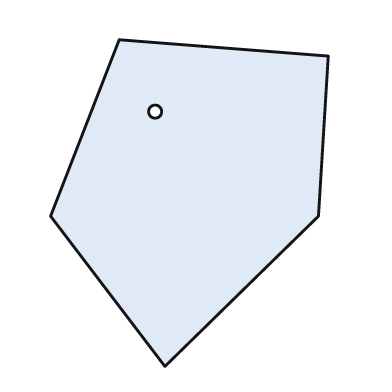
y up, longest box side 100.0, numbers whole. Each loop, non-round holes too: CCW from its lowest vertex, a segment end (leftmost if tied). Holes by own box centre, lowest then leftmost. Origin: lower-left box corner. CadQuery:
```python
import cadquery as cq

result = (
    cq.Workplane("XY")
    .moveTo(35.0, 0.0)
    .lineTo(82.0, 46.0)
    .lineTo(85.0, 95.0)
    .lineTo(21.0, 100.0)
    .lineTo(0.0, 46.0)
    .close()
    .moveTo(32.0, 78.0)
    .circle(2.0)
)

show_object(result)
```